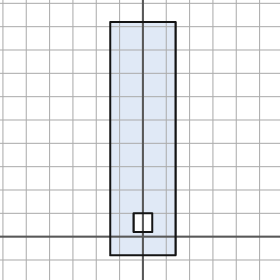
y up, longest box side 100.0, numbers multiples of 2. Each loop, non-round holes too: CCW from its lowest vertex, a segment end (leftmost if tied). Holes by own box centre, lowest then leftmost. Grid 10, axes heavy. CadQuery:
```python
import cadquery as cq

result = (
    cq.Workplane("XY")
    .moveTo(-14.0, -8.0)
    .lineTo(14.0, -8.0)
    .lineTo(14.0, 92.0)
    .lineTo(-14.0, 92.0)
    .close()
    .moveTo(-4.0, 2.0)
    .lineTo(4.0, 2.0)
    .lineTo(4.0, 10.0)
    .lineTo(-4.0, 10.0)
    .close()
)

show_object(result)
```